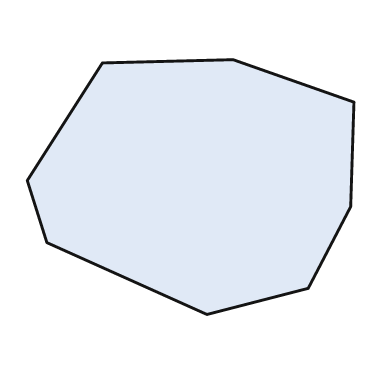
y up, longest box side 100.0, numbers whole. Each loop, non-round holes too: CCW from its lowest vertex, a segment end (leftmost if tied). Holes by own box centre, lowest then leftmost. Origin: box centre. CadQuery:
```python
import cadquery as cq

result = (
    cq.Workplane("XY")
    .moveTo(5.0, -39.0)
    .lineTo(36.0, -31.0)
    .lineTo(49.0, -6.0)
    .lineTo(50.0, 26.0)
    .lineTo(13.0, 39.0)
    .lineTo(-27.0, 38.0)
    .lineTo(-50.0, 2.0)
    .lineTo(-44.0, -17.0)
    .close()
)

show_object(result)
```